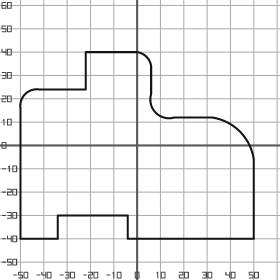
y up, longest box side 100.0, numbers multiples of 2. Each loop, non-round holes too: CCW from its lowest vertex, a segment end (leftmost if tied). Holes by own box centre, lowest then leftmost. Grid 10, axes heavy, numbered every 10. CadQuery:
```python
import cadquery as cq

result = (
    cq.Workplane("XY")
    .moveTo(-50.0, -40.0)
    .lineTo(-34.0, -40.0)
    .lineTo(-34.0, -30.0)
    .lineTo(-4.0, -30.0)
    .lineTo(-4.0, -40.0)
    .lineTo(50.0, -40.0)
    .lineTo(50.0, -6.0)
    .threePointArc((44.0, 6.0), (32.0, 12.0))
    .lineTo(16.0, 12.0)
    .threePointArc((8.0, 14.0), (6.0, 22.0))
    .lineTo(6.0, 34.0)
    .threePointArc((4.0, 38.0), (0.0, 40.0))
    .lineTo(-22.0, 40.0)
    .lineTo(-22.0, 24.0)
    .lineTo(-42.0, 24.0)
    .threePointArc((-48.0, 22.0), (-50.0, 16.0))
    .close()
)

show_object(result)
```